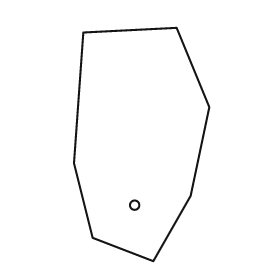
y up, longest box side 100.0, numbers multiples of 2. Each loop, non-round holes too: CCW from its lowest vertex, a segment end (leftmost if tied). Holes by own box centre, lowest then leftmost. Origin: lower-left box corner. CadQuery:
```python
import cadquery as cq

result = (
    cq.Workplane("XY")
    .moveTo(34.0, 0.0)
    .lineTo(50.0, 28.0)
    .lineTo(58.0, 66.0)
    .lineTo(44.0, 100.0)
    .lineTo(4.0, 98.0)
    .lineTo(0.0, 42.0)
    .lineTo(8.0, 10.0)
    .close()
    .moveTo(26.0, 24.0)
    .circle(2.0)
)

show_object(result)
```